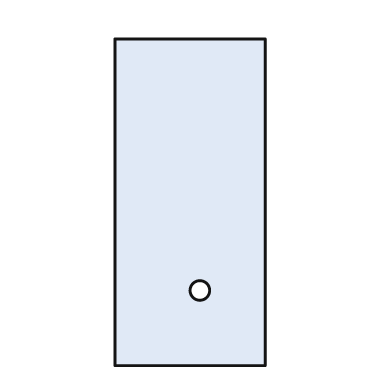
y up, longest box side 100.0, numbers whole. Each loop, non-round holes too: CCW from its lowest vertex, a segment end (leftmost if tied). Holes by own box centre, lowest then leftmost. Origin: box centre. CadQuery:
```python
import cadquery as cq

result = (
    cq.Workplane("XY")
    .moveTo(-23.0, -50.0)
    .lineTo(23.0, -50.0)
    .lineTo(23.0, 50.0)
    .lineTo(-23.0, 50.0)
    .close()
    .moveTo(3.0, -27.0)
    .circle(3.0)
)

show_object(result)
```